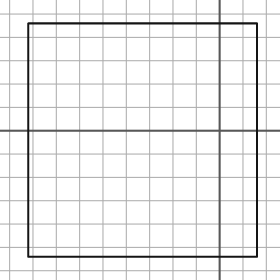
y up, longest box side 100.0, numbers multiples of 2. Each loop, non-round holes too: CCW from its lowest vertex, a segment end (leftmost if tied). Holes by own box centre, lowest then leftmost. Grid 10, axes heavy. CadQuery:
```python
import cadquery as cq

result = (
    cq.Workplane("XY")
    .moveTo(-82.0, -54.0)
    .lineTo(16.0, -54.0)
    .lineTo(16.0, 46.0)
    .lineTo(-82.0, 46.0)
    .close()
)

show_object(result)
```